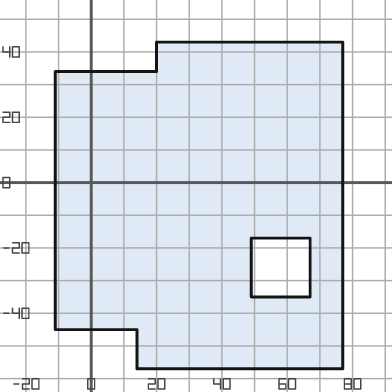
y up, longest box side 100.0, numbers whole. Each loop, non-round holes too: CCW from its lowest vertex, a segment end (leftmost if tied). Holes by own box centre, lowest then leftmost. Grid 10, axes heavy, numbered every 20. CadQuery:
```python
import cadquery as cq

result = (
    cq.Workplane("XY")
    .moveTo(14.0, -57.0)
    .lineTo(77.0, -57.0)
    .lineTo(77.0, 43.0)
    .lineTo(20.0, 43.0)
    .lineTo(20.0, 34.0)
    .lineTo(-11.0, 34.0)
    .lineTo(-11.0, -45.0)
    .lineTo(14.0, -45.0)
    .close()
    .moveTo(49.0, -35.0)
    .lineTo(67.0, -35.0)
    .lineTo(67.0, -17.0)
    .lineTo(49.0, -17.0)
    .close()
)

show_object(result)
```